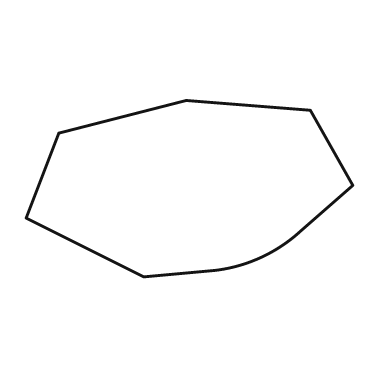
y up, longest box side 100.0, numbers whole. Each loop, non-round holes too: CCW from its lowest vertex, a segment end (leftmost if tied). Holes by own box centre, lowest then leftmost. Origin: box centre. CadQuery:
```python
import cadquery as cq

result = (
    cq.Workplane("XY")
    .moveTo(-14.0, -27.0)
    .lineTo(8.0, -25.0)
    .threePointArc((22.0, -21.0), (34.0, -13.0))
    .lineTo(50.0, 1.0)
    .lineTo(37.0, 24.0)
    .lineTo(-1.0, 27.0)
    .lineTo(-40.0, 17.0)
    .lineTo(-50.0, -9.0)
    .close()
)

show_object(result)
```